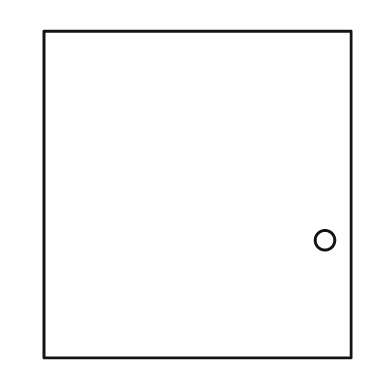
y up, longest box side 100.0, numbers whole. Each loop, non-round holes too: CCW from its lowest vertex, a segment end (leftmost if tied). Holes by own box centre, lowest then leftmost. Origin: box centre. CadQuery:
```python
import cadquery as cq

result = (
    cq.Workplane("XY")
    .moveTo(-47.0, -50.0)
    .lineTo(47.0, -50.0)
    .lineTo(47.0, 50.0)
    .lineTo(-47.0, 50.0)
    .close()
    .moveTo(39.0, -14.0)
    .circle(3.0)
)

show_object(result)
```